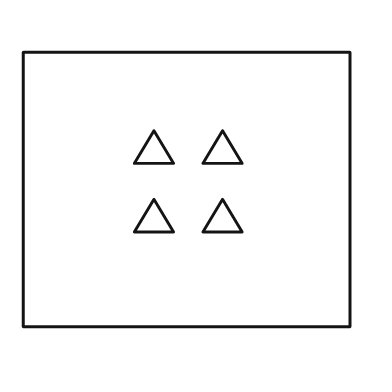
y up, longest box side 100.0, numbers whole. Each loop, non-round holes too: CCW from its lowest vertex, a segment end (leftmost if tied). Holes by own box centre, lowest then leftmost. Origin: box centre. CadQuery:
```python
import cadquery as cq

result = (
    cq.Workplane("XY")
    .moveTo(-50.0, -42.0)
    .lineTo(50.0, -42.0)
    .lineTo(50.0, 42.0)
    .lineTo(-50.0, 42.0)
    .close()
    .moveTo(-16.0, -13.0)
    .lineTo(-4.0, -13.0)
    .lineTo(-10.0, -3.0)
    .close()
    .moveTo(5.0, -13.0)
    .lineTo(17.0, -13.0)
    .lineTo(11.0, -3.0)
    .close()
    .moveTo(-16.0, 8.0)
    .lineTo(-4.0, 8.0)
    .lineTo(-10.0, 18.0)
    .close()
    .moveTo(5.0, 8.0)
    .lineTo(17.0, 8.0)
    .lineTo(11.0, 18.0)
    .close()
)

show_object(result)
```